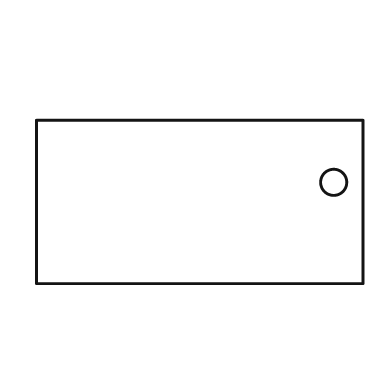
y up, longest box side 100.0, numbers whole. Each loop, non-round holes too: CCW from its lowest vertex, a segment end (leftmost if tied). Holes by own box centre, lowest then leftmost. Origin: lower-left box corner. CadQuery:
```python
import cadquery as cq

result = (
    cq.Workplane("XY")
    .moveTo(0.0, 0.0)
    .lineTo(100.0, 0.0)
    .lineTo(100.0, 50.0)
    .lineTo(0.0, 50.0)
    .close()
    .moveTo(91.0, 31.0)
    .circle(4.0)
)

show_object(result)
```